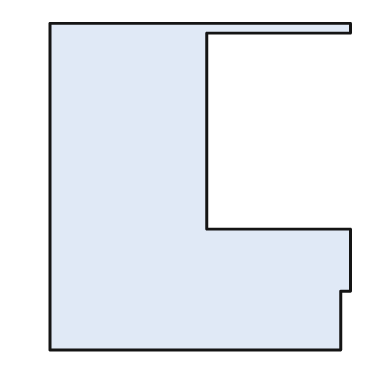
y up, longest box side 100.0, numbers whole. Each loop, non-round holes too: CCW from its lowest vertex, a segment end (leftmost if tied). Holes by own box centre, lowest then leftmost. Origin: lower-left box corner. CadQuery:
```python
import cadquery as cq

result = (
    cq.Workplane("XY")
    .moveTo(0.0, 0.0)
    .lineTo(89.0, 0.0)
    .lineTo(89.0, 18.0)
    .lineTo(92.0, 18.0)
    .lineTo(92.0, 37.0)
    .lineTo(48.0, 37.0)
    .lineTo(48.0, 97.0)
    .lineTo(92.0, 97.0)
    .lineTo(92.0, 100.0)
    .lineTo(0.0, 100.0)
    .close()
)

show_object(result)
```